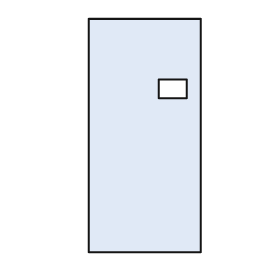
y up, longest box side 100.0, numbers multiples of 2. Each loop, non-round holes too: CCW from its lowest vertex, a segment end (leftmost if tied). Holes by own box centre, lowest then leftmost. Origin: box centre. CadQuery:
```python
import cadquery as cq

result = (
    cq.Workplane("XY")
    .moveTo(-24.0, -50.0)
    .lineTo(24.0, -50.0)
    .lineTo(24.0, 50.0)
    .lineTo(-24.0, 50.0)
    .close()
    .moveTo(6.0, 16.0)
    .lineTo(18.0, 16.0)
    .lineTo(18.0, 24.0)
    .lineTo(6.0, 24.0)
    .close()
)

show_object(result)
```